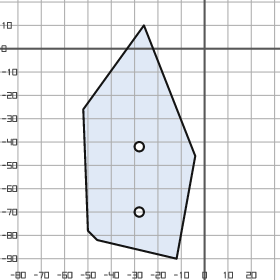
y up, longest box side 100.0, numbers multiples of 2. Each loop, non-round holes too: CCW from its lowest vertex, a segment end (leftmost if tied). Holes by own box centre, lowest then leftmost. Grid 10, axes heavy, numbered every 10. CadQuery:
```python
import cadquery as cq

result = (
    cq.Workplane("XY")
    .moveTo(-12.0, -90.0)
    .lineTo(-4.0, -46.0)
    .lineTo(-26.0, 10.0)
    .lineTo(-52.0, -26.0)
    .lineTo(-50.0, -78.0)
    .lineTo(-46.0, -82.0)
    .close()
    .moveTo(-28.0, -70.0)
    .circle(2.0)
    .moveTo(-28.0, -42.0)
    .circle(2.0)
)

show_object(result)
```